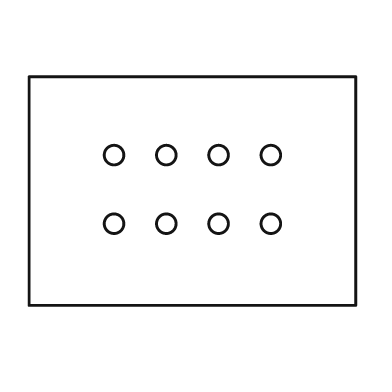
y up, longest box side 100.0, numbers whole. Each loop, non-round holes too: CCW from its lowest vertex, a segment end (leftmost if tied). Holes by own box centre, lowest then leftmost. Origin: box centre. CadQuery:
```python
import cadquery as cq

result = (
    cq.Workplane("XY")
    .moveTo(-50.0, -35.0)
    .lineTo(50.0, -35.0)
    .lineTo(50.0, 35.0)
    .lineTo(-50.0, 35.0)
    .close()
    .moveTo(-24.0, -10.0)
    .circle(3.0)
    .moveTo(-8.0, -10.0)
    .circle(3.0)
    .moveTo(8.0, -10.0)
    .circle(3.0)
    .moveTo(24.0, -10.0)
    .circle(3.0)
    .moveTo(-24.0, 11.0)
    .circle(3.0)
    .moveTo(-8.0, 11.0)
    .circle(3.0)
    .moveTo(8.0, 11.0)
    .circle(3.0)
    .moveTo(24.0, 11.0)
    .circle(3.0)
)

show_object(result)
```